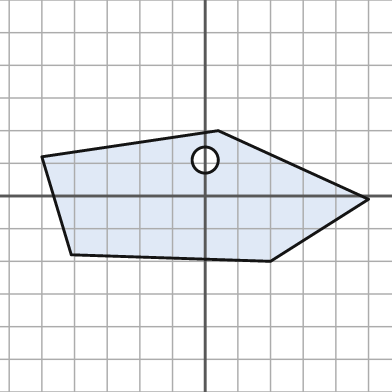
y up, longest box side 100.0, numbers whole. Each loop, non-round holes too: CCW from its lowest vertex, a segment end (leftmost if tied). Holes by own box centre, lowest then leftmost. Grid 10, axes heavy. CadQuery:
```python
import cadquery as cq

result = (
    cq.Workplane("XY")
    .moveTo(20.0, -20.0)
    .lineTo(50.0, -1.0)
    .lineTo(4.0, 20.0)
    .lineTo(-50.0, 12.0)
    .lineTo(-41.0, -18.0)
    .close()
    .moveTo(0.0, 11.0)
    .circle(4.0)
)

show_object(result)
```